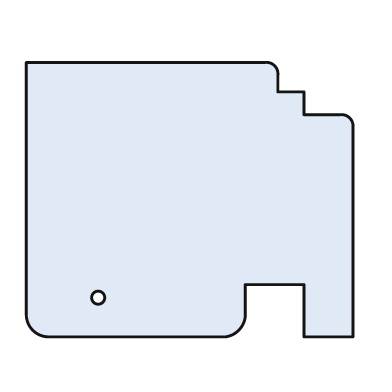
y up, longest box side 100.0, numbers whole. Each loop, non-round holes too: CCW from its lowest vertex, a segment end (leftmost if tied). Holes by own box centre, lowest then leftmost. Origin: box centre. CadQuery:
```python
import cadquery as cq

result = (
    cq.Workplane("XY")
    .moveTo(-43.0, -42.0)
    .lineTo(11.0, -42.0)
    .threePointArc((15.0, -40.0), (17.0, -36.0))
    .lineTo(17.0, -26.0)
    .lineTo(35.0, -26.0)
    .lineTo(35.0, -42.0)
    .lineTo(50.0, -42.0)
    .lineTo(50.0, 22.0)
    .threePointArc((49.0, 25.0), (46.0, 26.0))
    .lineTo(35.0, 26.0)
    .lineTo(35.0, 33.0)
    .lineTo(27.0, 33.0)
    .lineTo(27.0, 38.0)
    .threePointArc((26.0, 41.0), (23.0, 42.0))
    .lineTo(-50.0, 42.0)
    .lineTo(-50.0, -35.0)
    .threePointArc((-48.0, -40.0), (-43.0, -42.0))
    .close()
    .moveTo(-28.0, -30.0)
    .circle(2.0)
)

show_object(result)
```